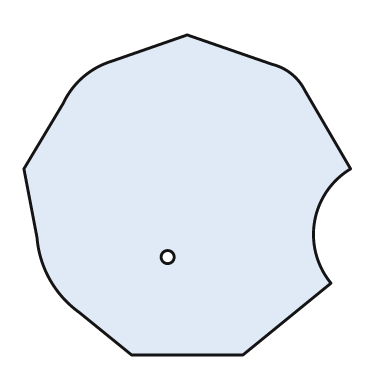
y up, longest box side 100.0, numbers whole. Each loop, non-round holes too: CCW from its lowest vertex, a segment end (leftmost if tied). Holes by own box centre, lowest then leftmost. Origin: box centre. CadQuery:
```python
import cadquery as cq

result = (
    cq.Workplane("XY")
    .moveTo(-17.0, -49.0)
    .lineTo(17.0, -49.0)
    .lineTo(44.0, -27.0)
    .threePointArc((39.0, -8.0), (50.0, 8.0))
    .lineTo(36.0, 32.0)
    .threePointArc((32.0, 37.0), (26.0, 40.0))
    .lineTo(0.0, 49.0)
    .lineTo(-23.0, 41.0)
    .threePointArc((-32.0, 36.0), (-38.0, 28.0))
    .lineTo(-50.0, 8.0)
    .lineTo(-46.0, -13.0)
    .threePointArc((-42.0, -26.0), (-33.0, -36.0))
    .close()
    .moveTo(-6.0, -19.0)
    .circle(2.0)
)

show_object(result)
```